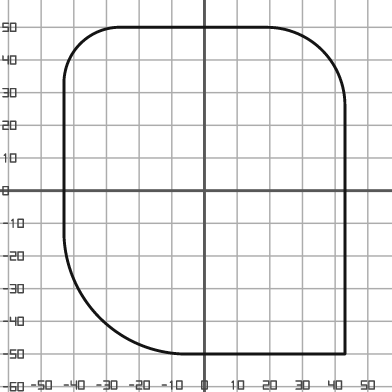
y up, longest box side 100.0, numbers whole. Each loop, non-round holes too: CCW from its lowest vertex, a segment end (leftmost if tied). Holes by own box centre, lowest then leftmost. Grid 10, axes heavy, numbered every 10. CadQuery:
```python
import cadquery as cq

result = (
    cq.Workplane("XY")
    .moveTo(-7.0, -50.0)
    .lineTo(43.0, -50.0)
    .lineTo(43.0, 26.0)
    .threePointArc((36.0, 43.0), (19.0, 50.0))
    .lineTo(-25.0, 50.0)
    .threePointArc((-38.0, 45.0), (-43.0, 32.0))
    .lineTo(-43.0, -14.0)
    .threePointArc((-32.0, -39.0), (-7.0, -50.0))
    .close()
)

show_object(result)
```